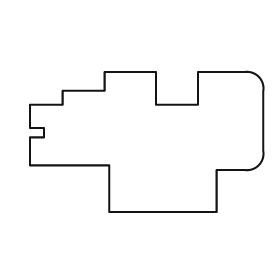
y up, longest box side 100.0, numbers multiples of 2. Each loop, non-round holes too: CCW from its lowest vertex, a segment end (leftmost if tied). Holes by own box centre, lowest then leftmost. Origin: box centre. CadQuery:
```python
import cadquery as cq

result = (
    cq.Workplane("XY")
    .moveTo(-16.0, -30.0)
    .lineTo(30.0, -30.0)
    .lineTo(30.0, -12.0)
    .lineTo(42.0, -12.0)
    .threePointArc((48.0, -10.0), (50.0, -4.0))
    .lineTo(50.0, 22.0)
    .threePointArc((48.0, 28.0), (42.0, 30.0))
    .lineTo(22.0, 30.0)
    .lineTo(22.0, 16.0)
    .lineTo(4.0, 16.0)
    .lineTo(4.0, 30.0)
    .lineTo(-18.0, 30.0)
    .lineTo(-18.0, 22.0)
    .lineTo(-36.0, 22.0)
    .lineTo(-36.0, 16.0)
    .lineTo(-50.0, 16.0)
    .lineTo(-50.0, 6.0)
    .lineTo(-44.0, 6.0)
    .lineTo(-44.0, 2.0)
    .lineTo(-50.0, 2.0)
    .lineTo(-50.0, -10.0)
    .lineTo(-16.0, -10.0)
    .close()
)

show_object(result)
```